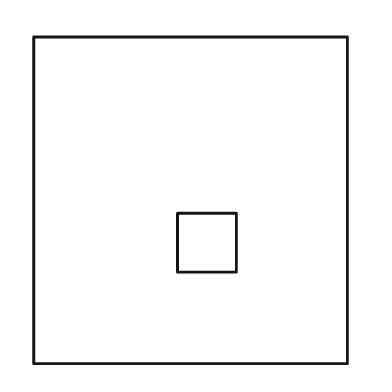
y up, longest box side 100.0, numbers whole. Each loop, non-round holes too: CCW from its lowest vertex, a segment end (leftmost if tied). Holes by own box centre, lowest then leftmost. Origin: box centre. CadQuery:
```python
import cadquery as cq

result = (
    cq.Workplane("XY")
    .moveTo(-48.0, -50.0)
    .lineTo(48.0, -50.0)
    .lineTo(48.0, 50.0)
    .lineTo(-48.0, 50.0)
    .close()
    .moveTo(-4.0, -22.0)
    .lineTo(14.0, -22.0)
    .lineTo(14.0, -4.0)
    .lineTo(-4.0, -4.0)
    .close()
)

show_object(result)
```